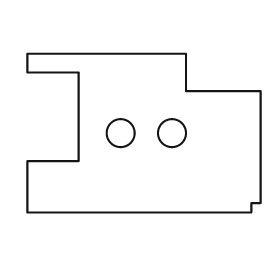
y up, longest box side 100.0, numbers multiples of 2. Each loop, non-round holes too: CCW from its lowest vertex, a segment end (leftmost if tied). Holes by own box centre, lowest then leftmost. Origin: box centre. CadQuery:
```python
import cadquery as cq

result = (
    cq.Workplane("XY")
    .moveTo(-50.0, -34.0)
    .lineTo(46.0, -34.0)
    .lineTo(46.0, -30.0)
    .lineTo(50.0, -30.0)
    .lineTo(50.0, 18.0)
    .lineTo(18.0, 18.0)
    .lineTo(18.0, 34.0)
    .lineTo(-50.0, 34.0)
    .lineTo(-50.0, 26.0)
    .lineTo(-28.0, 26.0)
    .lineTo(-28.0, -12.0)
    .lineTo(-50.0, -12.0)
    .close()
    .moveTo(-10.0, 0.0)
    .circle(6.0)
    .moveTo(12.0, 0.0)
    .circle(6.0)
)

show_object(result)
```